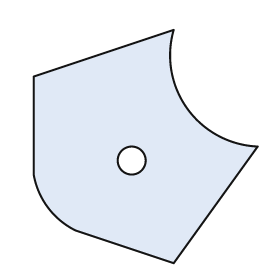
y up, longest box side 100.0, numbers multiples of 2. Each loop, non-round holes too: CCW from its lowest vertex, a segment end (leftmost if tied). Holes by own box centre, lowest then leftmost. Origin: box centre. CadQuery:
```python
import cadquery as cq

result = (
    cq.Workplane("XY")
    .moveTo(12.0, -50.0)
    .lineTo(48.0, 0.0)
    .threePointArc((18.0, 16.0), (12.0, 50.0))
    .lineTo(-48.0, 30.0)
    .lineTo(-48.0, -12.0)
    .threePointArc((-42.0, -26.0), (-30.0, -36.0))
    .close()
    .moveTo(-6.0, -6.0)
    .circle(6.0)
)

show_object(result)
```